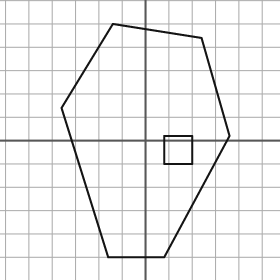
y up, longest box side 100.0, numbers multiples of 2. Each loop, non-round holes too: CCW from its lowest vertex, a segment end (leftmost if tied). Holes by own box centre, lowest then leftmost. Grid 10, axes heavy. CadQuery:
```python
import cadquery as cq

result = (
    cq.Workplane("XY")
    .moveTo(-16.0, -50.0)
    .lineTo(8.0, -50.0)
    .lineTo(36.0, 2.0)
    .lineTo(24.0, 44.0)
    .lineTo(-14.0, 50.0)
    .lineTo(-36.0, 14.0)
    .close()
    .moveTo(8.0, -10.0)
    .lineTo(20.0, -10.0)
    .lineTo(20.0, 2.0)
    .lineTo(8.0, 2.0)
    .close()
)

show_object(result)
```